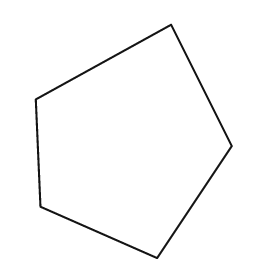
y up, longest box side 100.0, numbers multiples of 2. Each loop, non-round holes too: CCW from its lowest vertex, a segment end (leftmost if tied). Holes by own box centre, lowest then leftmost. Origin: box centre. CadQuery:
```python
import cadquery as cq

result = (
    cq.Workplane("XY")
    .moveTo(10.0, -50.0)
    .lineTo(42.0, -2.0)
    .lineTo(16.0, 50.0)
    .lineTo(-42.0, 18.0)
    .lineTo(-40.0, -28.0)
    .close()
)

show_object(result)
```